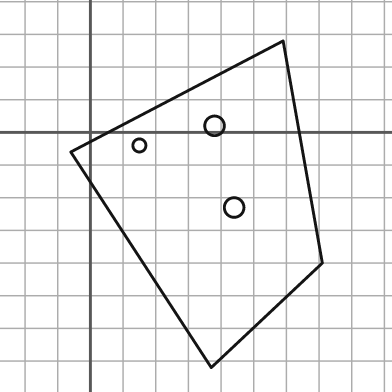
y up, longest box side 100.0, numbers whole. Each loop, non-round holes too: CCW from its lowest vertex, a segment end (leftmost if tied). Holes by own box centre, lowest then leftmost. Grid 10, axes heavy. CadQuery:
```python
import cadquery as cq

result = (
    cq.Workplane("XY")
    .moveTo(37.0, -72.0)
    .lineTo(71.0, -40.0)
    .lineTo(59.0, 28.0)
    .lineTo(-6.0, -6.0)
    .close()
    .moveTo(44.0, -23.0)
    .circle(3.0)
    .moveTo(15.0, -4.0)
    .circle(2.0)
    .moveTo(38.0, 2.0)
    .circle(3.0)
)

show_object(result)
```